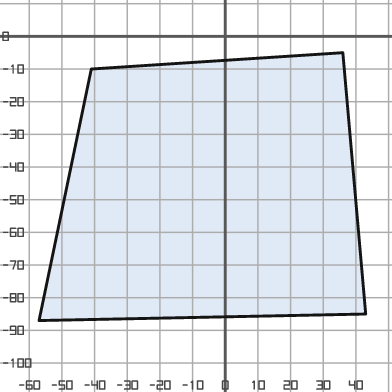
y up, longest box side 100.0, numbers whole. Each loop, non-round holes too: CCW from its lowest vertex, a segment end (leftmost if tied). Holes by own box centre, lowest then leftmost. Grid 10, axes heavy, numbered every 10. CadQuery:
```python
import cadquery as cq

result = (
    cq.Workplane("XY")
    .moveTo(-57.0, -87.0)
    .lineTo(43.0, -85.0)
    .lineTo(36.0, -5.0)
    .lineTo(-41.0, -10.0)
    .close()
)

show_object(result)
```